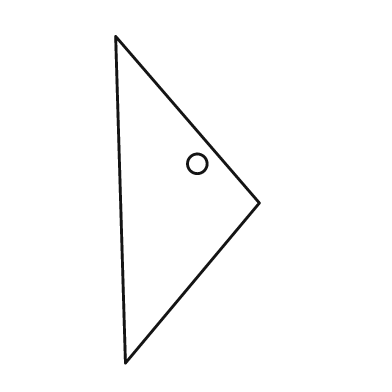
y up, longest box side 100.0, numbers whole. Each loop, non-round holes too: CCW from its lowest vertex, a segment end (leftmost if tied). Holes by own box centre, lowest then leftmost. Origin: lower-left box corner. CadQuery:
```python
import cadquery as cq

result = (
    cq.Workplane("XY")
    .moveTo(3.0, 0.0)
    .lineTo(44.0, 49.0)
    .lineTo(0.0, 100.0)
    .close()
    .moveTo(25.0, 61.0)
    .circle(3.0)
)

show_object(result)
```